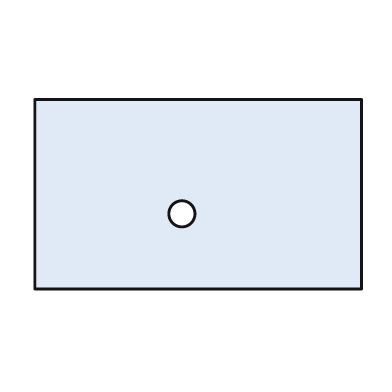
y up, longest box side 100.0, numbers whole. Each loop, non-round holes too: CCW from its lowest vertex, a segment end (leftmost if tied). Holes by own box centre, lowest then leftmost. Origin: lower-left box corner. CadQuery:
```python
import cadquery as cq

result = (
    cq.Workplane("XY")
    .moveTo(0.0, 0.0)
    .lineTo(100.0, 0.0)
    .lineTo(100.0, 58.0)
    .lineTo(0.0, 58.0)
    .close()
    .moveTo(45.0, 23.0)
    .circle(4.0)
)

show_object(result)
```